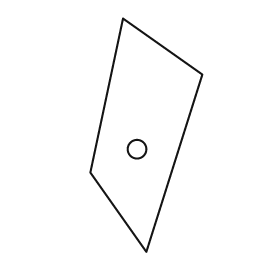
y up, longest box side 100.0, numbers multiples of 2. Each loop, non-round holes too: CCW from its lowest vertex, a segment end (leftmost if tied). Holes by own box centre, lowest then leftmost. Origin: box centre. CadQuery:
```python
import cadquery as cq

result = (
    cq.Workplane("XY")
    .moveTo(0.0, -50.0)
    .lineTo(24.0, 26.0)
    .lineTo(-10.0, 50.0)
    .lineTo(-24.0, -16.0)
    .close()
    .moveTo(-4.0, -6.0)
    .circle(4.0)
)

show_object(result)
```